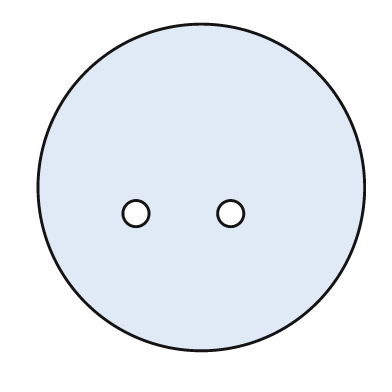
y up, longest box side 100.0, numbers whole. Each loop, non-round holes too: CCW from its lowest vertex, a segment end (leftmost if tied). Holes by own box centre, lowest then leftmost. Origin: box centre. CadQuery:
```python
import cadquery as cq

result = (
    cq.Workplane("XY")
    .moveTo(0.0, 0.0)
    .circle(50.0)
    .moveTo(-20.0, -8.0)
    .circle(4.0)
    .moveTo(9.0, -8.0)
    .circle(4.0)
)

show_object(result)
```